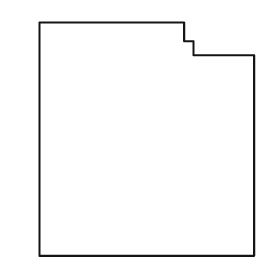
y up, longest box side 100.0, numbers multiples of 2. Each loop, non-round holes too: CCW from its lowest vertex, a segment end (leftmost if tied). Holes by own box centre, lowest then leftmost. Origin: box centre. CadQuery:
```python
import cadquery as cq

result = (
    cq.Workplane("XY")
    .moveTo(-46.0, -50.0)
    .lineTo(46.0, -50.0)
    .lineTo(46.0, 36.0)
    .lineTo(20.0, 36.0)
    .lineTo(20.0, 42.0)
    .lineTo(16.0, 42.0)
    .lineTo(16.0, 50.0)
    .lineTo(-46.0, 50.0)
    .close()
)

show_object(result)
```